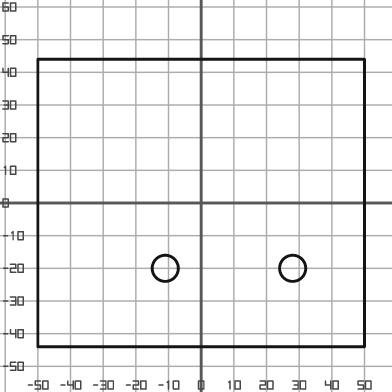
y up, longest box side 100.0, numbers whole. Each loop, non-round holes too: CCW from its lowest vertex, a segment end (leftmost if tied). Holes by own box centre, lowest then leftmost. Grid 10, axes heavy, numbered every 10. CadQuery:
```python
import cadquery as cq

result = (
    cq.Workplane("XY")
    .moveTo(-50.0, -44.0)
    .lineTo(50.0, -44.0)
    .lineTo(50.0, 44.0)
    .lineTo(-50.0, 44.0)
    .close()
    .moveTo(-11.0, -20.0)
    .circle(4.0)
    .moveTo(28.0, -20.0)
    .circle(4.0)
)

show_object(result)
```